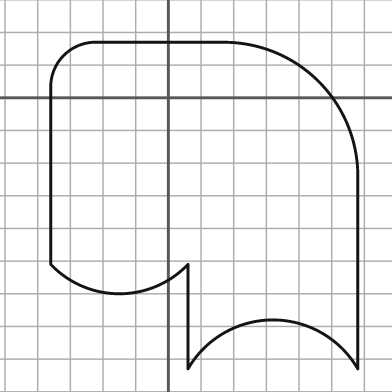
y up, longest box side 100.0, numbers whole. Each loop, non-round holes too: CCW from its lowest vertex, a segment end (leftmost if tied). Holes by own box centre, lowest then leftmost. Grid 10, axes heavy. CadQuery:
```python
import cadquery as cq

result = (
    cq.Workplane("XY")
    .moveTo(6.0, -83.0)
    .threePointArc((32.0, -68.0), (58.0, -83.0))
    .lineTo(58.0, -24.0)
    .threePointArc((46.0, 5.0), (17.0, 17.0))
    .lineTo(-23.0, 17.0)
    .threePointArc((-32.0, 13.0), (-36.0, 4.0))
    .lineTo(-36.0, -51.0)
    .threePointArc((-15.0, -60.0), (6.0, -51.0))
    .close()
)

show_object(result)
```